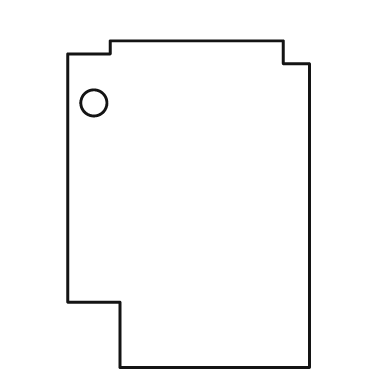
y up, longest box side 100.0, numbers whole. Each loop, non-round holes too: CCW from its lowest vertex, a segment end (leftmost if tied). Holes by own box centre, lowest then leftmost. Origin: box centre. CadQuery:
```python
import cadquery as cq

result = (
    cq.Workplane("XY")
    .moveTo(-21.0, -50.0)
    .lineTo(37.0, -50.0)
    .lineTo(37.0, 43.0)
    .lineTo(29.0, 43.0)
    .lineTo(29.0, 50.0)
    .lineTo(-24.0, 50.0)
    .lineTo(-24.0, 46.0)
    .lineTo(-37.0, 46.0)
    .lineTo(-37.0, -30.0)
    .lineTo(-21.0, -30.0)
    .close()
    .moveTo(-29.0, 31.0)
    .circle(4.0)
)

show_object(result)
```